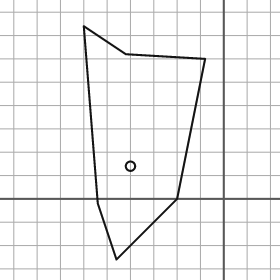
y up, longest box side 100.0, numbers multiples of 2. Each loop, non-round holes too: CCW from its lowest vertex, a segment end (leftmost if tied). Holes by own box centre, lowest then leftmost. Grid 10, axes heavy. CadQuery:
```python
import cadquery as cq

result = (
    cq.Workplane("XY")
    .moveTo(-46.0, -26.0)
    .lineTo(-20.0, 0.0)
    .lineTo(-8.0, 60.0)
    .lineTo(-42.0, 62.0)
    .lineTo(-60.0, 74.0)
    .lineTo(-54.0, -2.0)
    .close()
    .moveTo(-40.0, 14.0)
    .circle(2.0)
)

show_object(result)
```